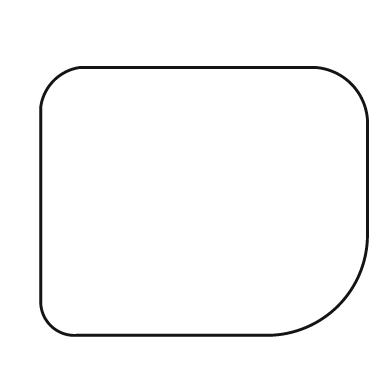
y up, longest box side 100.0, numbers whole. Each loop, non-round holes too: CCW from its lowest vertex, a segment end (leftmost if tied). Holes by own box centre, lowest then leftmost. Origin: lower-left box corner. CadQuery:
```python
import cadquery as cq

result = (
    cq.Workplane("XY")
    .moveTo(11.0, 0.0)
    .lineTo(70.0, 0.0)
    .threePointArc((91.0, 9.0), (100.0, 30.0))
    .lineTo(100.0, 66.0)
    .threePointArc((95.0, 77.0), (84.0, 82.0))
    .lineTo(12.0, 82.0)
    .threePointArc((4.0, 78.0), (0.0, 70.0))
    .lineTo(0.0, 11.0)
    .threePointArc((3.0, 3.0), (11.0, 0.0))
    .close()
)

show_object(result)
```